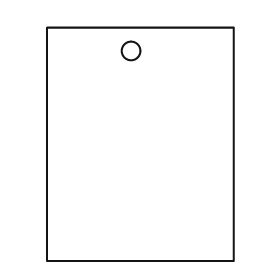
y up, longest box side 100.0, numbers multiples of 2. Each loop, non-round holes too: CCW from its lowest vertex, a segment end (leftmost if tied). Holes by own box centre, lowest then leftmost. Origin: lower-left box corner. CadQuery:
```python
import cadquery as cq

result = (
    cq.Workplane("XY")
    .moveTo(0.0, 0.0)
    .lineTo(80.0, 0.0)
    .lineTo(80.0, 100.0)
    .lineTo(0.0, 100.0)
    .close()
    .moveTo(36.0, 90.0)
    .circle(4.0)
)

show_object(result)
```